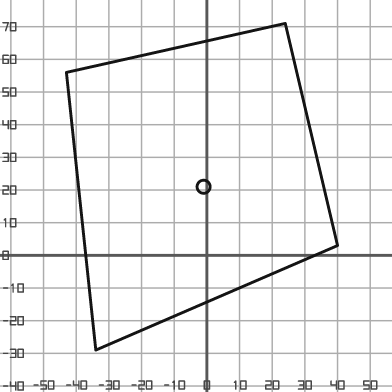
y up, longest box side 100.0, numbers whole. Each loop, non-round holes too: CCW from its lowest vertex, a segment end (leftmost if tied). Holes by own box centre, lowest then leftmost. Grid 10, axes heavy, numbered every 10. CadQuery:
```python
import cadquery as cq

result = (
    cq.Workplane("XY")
    .moveTo(-34.0, -29.0)
    .lineTo(40.0, 3.0)
    .lineTo(24.0, 71.0)
    .lineTo(-43.0, 56.0)
    .close()
    .moveTo(-1.0, 21.0)
    .circle(2.0)
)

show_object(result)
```